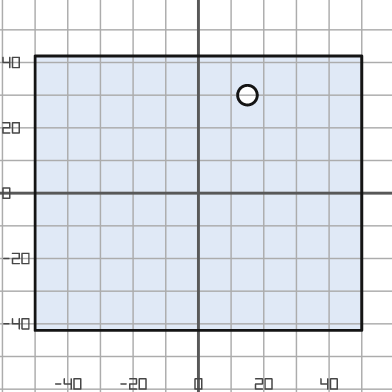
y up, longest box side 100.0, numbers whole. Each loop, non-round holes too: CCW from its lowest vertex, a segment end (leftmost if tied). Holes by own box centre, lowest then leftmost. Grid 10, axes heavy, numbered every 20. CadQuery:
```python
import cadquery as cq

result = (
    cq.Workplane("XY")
    .moveTo(-50.0, -42.0)
    .lineTo(50.0, -42.0)
    .lineTo(50.0, 42.0)
    .lineTo(-50.0, 42.0)
    .close()
    .moveTo(15.0, 30.0)
    .circle(3.0)
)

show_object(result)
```